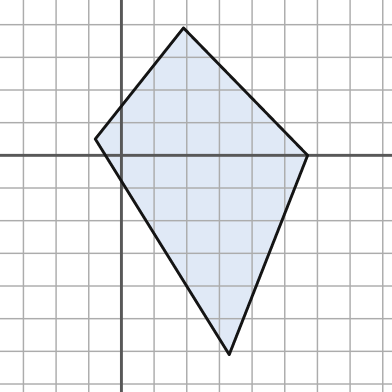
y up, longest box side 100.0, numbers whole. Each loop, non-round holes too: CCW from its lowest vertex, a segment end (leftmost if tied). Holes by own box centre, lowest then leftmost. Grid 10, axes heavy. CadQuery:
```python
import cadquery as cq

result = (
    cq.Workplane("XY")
    .moveTo(33.0, -61.0)
    .lineTo(57.0, 0.0)
    .lineTo(19.0, 39.0)
    .lineTo(-8.0, 5.0)
    .close()
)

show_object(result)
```